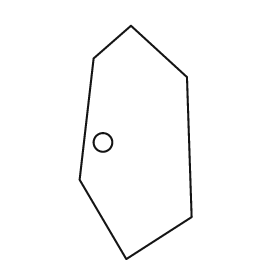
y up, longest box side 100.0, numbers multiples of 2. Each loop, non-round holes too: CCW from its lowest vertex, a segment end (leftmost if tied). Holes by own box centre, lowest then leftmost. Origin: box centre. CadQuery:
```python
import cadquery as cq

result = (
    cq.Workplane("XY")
    .moveTo(-4.0, -50.0)
    .lineTo(24.0, -32.0)
    .lineTo(22.0, 28.0)
    .lineTo(-2.0, 50.0)
    .lineTo(-18.0, 36.0)
    .lineTo(-24.0, -16.0)
    .close()
    .moveTo(-14.0, 0.0)
    .circle(4.0)
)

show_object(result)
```